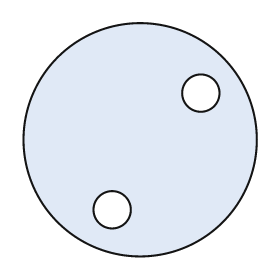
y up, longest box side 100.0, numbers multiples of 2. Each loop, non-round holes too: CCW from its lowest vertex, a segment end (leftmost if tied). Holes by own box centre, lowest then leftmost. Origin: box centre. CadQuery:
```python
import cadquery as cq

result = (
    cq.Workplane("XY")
    .moveTo(0.0, 0.0)
    .circle(50.0)
    .moveTo(-12.0, -30.0)
    .circle(8.0)
    .moveTo(26.0, 20.0)
    .circle(8.0)
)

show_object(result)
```